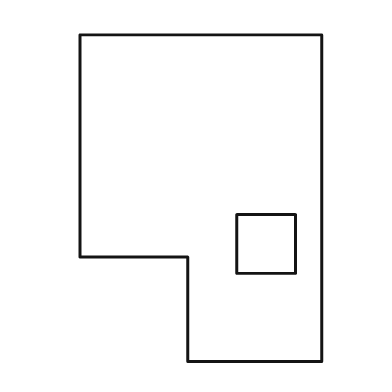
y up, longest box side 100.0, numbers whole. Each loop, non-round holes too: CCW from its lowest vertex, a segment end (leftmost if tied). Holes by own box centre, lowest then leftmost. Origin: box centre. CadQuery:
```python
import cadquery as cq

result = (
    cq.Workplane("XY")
    .moveTo(-4.0, -50.0)
    .lineTo(37.0, -50.0)
    .lineTo(37.0, 50.0)
    .lineTo(-37.0, 50.0)
    .lineTo(-37.0, -18.0)
    .lineTo(-4.0, -18.0)
    .close()
    .moveTo(11.0, -23.0)
    .lineTo(29.0, -23.0)
    .lineTo(29.0, -5.0)
    .lineTo(11.0, -5.0)
    .close()
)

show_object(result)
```